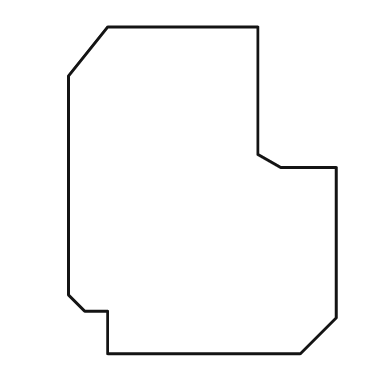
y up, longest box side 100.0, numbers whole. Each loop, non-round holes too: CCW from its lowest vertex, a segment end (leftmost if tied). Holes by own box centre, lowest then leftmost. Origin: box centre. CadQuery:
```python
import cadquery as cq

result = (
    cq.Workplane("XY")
    .moveTo(-29.0, -50.0)
    .lineTo(30.0, -50.0)
    .lineTo(41.0, -39.0)
    .lineTo(41.0, 7.0)
    .lineTo(24.0, 7.0)
    .lineTo(17.0, 11.0)
    .lineTo(17.0, 50.0)
    .lineTo(-29.0, 50.0)
    .lineTo(-41.0, 35.0)
    .lineTo(-41.0, -32.0)
    .lineTo(-36.0, -37.0)
    .lineTo(-29.0, -37.0)
    .close()
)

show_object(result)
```